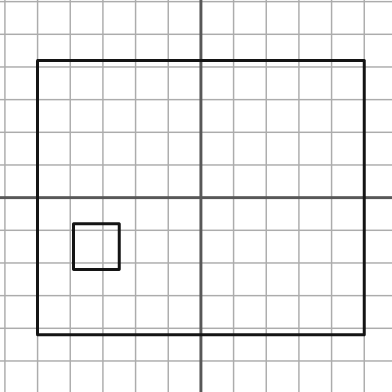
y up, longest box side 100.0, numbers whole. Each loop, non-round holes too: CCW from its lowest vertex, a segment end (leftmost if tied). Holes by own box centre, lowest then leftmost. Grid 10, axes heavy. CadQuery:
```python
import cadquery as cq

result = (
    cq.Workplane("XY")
    .moveTo(-50.0, -42.0)
    .lineTo(50.0, -42.0)
    .lineTo(50.0, 42.0)
    .lineTo(-50.0, 42.0)
    .close()
    .moveTo(-39.0, -22.0)
    .lineTo(-25.0, -22.0)
    .lineTo(-25.0, -8.0)
    .lineTo(-39.0, -8.0)
    .close()
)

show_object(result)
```